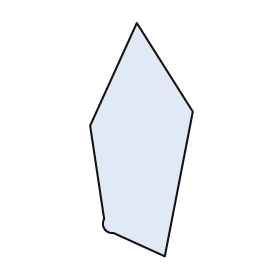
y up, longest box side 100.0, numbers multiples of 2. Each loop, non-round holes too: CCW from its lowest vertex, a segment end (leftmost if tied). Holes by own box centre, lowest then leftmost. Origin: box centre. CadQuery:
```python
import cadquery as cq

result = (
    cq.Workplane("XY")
    .moveTo(10.0, -50.0)
    .lineTo(22.0, 12.0)
    .lineTo(-2.0, 50.0)
    .lineTo(-22.0, 6.0)
    .lineTo(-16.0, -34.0)
    .threePointArc((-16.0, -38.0), (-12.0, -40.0))
    .close()
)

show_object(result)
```